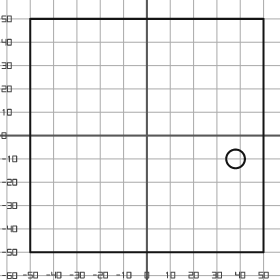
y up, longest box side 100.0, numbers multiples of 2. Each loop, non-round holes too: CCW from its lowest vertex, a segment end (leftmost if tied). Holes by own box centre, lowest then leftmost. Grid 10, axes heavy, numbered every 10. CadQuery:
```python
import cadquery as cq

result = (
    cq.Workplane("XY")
    .moveTo(-50.0, -50.0)
    .lineTo(50.0, -50.0)
    .lineTo(50.0, 50.0)
    .lineTo(-50.0, 50.0)
    .close()
    .moveTo(38.0, -10.0)
    .circle(4.0)
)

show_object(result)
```